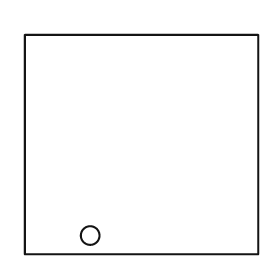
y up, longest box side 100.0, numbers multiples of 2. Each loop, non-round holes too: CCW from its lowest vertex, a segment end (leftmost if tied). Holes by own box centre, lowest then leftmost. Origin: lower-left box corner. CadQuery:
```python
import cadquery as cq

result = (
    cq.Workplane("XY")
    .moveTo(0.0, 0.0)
    .lineTo(100.0, 0.0)
    .lineTo(100.0, 94.0)
    .lineTo(0.0, 94.0)
    .close()
    .moveTo(28.0, 8.0)
    .circle(4.0)
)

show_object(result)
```